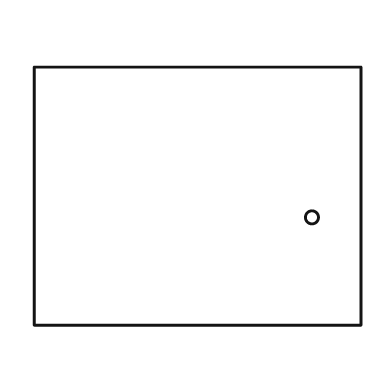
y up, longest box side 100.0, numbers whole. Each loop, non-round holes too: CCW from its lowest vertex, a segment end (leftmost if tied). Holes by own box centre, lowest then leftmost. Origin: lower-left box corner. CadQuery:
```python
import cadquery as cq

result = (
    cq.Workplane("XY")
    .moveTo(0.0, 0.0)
    .lineTo(100.0, 0.0)
    .lineTo(100.0, 79.0)
    .lineTo(0.0, 79.0)
    .close()
    .moveTo(85.0, 33.0)
    .circle(2.0)
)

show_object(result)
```